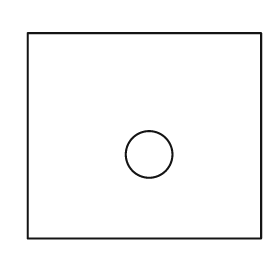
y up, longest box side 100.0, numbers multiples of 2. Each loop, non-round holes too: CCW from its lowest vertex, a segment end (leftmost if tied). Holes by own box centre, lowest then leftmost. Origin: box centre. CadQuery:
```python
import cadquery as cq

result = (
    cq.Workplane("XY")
    .moveTo(-50.0, -44.0)
    .lineTo(50.0, -44.0)
    .lineTo(50.0, 44.0)
    .lineTo(-50.0, 44.0)
    .close()
    .moveTo(2.0, -8.0)
    .circle(10.0)
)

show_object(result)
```